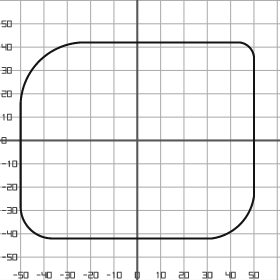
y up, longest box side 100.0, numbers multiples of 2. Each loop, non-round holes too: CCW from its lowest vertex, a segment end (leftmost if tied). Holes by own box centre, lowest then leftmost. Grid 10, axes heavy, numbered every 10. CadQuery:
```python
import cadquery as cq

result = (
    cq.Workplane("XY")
    .moveTo(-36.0, -42.0)
    .lineTo(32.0, -42.0)
    .threePointArc((44.0, -36.0), (50.0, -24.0))
    .lineTo(50.0, 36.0)
    .threePointArc((48.0, 40.0), (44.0, 42.0))
    .lineTo(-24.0, 42.0)
    .threePointArc((-42.0, 34.0), (-50.0, 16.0))
    .lineTo(-50.0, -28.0)
    .threePointArc((-46.0, -38.0), (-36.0, -42.0))
    .close()
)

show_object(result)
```